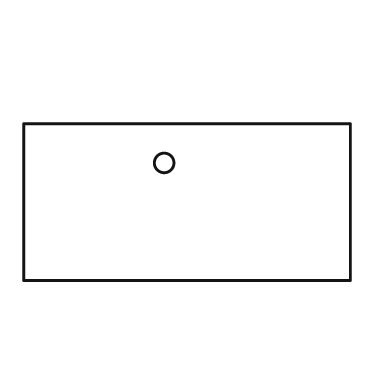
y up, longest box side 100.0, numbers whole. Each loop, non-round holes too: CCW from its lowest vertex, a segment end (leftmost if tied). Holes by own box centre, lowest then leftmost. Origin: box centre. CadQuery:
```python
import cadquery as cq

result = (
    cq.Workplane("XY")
    .moveTo(-50.0, -24.0)
    .lineTo(50.0, -24.0)
    .lineTo(50.0, 24.0)
    .lineTo(-50.0, 24.0)
    .close()
    .moveTo(-7.0, 12.0)
    .circle(3.0)
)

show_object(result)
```